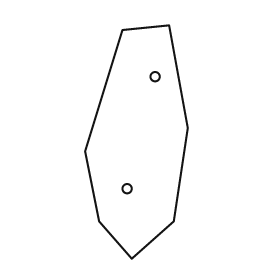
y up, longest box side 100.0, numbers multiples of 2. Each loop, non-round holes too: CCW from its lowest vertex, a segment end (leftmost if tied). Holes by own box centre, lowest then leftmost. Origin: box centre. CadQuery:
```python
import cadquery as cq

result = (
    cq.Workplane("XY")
    .moveTo(-2.0, -50.0)
    .lineTo(16.0, -34.0)
    .lineTo(22.0, 6.0)
    .lineTo(14.0, 50.0)
    .lineTo(-6.0, 48.0)
    .lineTo(-22.0, -4.0)
    .lineTo(-16.0, -34.0)
    .close()
    .moveTo(-4.0, -20.0)
    .circle(2.0)
    .moveTo(8.0, 28.0)
    .circle(2.0)
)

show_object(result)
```